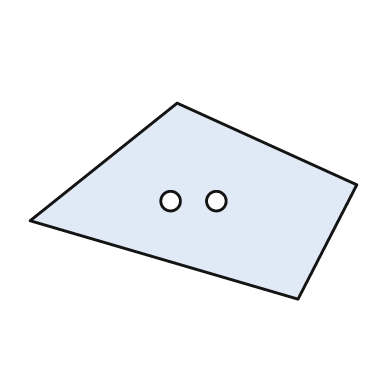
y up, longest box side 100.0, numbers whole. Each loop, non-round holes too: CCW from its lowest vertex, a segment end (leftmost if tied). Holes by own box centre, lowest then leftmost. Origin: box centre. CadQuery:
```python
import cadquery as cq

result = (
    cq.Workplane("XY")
    .moveTo(32.0, -30.0)
    .lineTo(50.0, 5.0)
    .lineTo(-5.0, 30.0)
    .lineTo(-50.0, -6.0)
    .close()
    .moveTo(-7.0, 0.0)
    .circle(3.0)
    .moveTo(7.0, 0.0)
    .circle(3.0)
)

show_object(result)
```